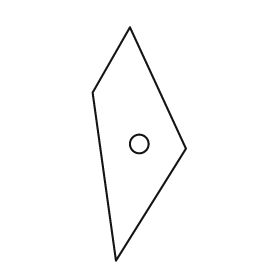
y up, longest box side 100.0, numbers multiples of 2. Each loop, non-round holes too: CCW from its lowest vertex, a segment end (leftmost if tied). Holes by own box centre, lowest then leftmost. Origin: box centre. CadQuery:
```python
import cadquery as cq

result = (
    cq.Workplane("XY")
    .moveTo(-10.0, -50.0)
    .lineTo(20.0, -2.0)
    .lineTo(-4.0, 50.0)
    .lineTo(-20.0, 22.0)
    .close()
    .moveTo(0.0, 0.0)
    .circle(4.0)
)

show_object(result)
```